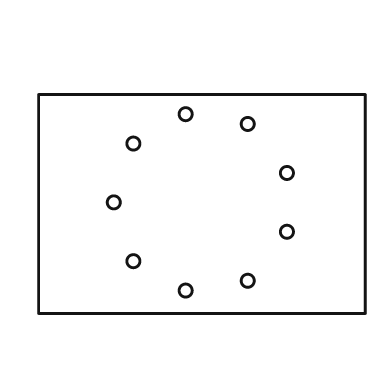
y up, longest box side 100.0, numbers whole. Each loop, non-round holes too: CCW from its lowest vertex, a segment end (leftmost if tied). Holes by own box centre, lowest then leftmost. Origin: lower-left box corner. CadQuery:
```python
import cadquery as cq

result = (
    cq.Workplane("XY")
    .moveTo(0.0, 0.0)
    .lineTo(100.0, 0.0)
    .lineTo(100.0, 67.0)
    .lineTo(0.0, 67.0)
    .close()
    .moveTo(45.0, 7.0)
    .circle(2.0)
    .moveTo(64.0, 10.0)
    .circle(2.0)
    .moveTo(29.0, 16.0)
    .circle(2.0)
    .moveTo(76.0, 25.0)
    .circle(2.0)
    .moveTo(23.0, 34.0)
    .circle(2.0)
    .moveTo(76.0, 43.0)
    .circle(2.0)
    .moveTo(29.0, 52.0)
    .circle(2.0)
    .moveTo(64.0, 58.0)
    .circle(2.0)
    .moveTo(45.0, 61.0)
    .circle(2.0)
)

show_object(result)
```